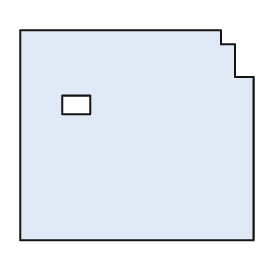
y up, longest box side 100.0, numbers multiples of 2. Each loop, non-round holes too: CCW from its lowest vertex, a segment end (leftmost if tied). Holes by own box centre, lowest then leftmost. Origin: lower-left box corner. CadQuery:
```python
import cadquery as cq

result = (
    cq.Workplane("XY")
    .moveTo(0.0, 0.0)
    .lineTo(100.0, 0.0)
    .lineTo(100.0, 70.0)
    .lineTo(92.0, 70.0)
    .lineTo(92.0, 84.0)
    .lineTo(86.0, 84.0)
    .lineTo(86.0, 90.0)
    .lineTo(0.0, 90.0)
    .close()
    .moveTo(18.0, 54.0)
    .lineTo(30.0, 54.0)
    .lineTo(30.0, 62.0)
    .lineTo(18.0, 62.0)
    .close()
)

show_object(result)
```